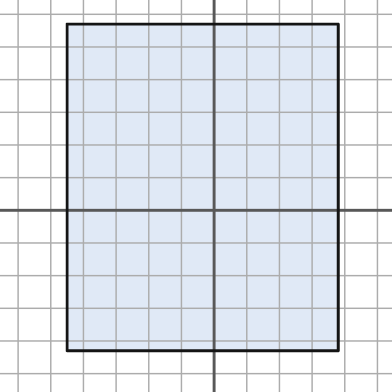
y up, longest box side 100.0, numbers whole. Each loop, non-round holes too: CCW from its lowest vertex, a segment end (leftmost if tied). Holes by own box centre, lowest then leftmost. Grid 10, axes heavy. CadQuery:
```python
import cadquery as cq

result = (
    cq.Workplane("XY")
    .moveTo(-45.0, -43.0)
    .lineTo(38.0, -43.0)
    .lineTo(38.0, 57.0)
    .lineTo(-45.0, 57.0)
    .close()
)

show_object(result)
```